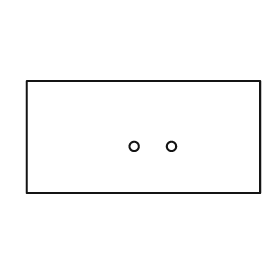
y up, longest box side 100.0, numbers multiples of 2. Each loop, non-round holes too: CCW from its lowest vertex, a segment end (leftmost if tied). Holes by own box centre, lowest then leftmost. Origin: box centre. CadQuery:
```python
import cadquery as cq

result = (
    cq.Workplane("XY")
    .moveTo(-50.0, -24.0)
    .lineTo(50.0, -24.0)
    .lineTo(50.0, 24.0)
    .lineTo(-50.0, 24.0)
    .close()
    .moveTo(-4.0, -4.0)
    .circle(2.0)
    .moveTo(12.0, -4.0)
    .circle(2.0)
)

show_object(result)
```